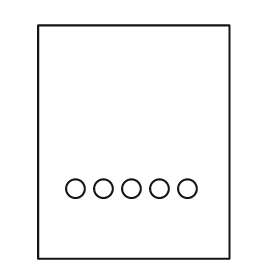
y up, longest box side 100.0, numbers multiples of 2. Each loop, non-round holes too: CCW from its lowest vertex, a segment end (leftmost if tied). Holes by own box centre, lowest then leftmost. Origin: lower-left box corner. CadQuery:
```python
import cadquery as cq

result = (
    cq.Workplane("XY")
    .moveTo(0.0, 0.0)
    .lineTo(82.0, 0.0)
    .lineTo(82.0, 100.0)
    .lineTo(0.0, 100.0)
    .close()
    .moveTo(16.0, 30.0)
    .circle(4.0)
    .moveTo(28.0, 30.0)
    .circle(4.0)
    .moveTo(40.0, 30.0)
    .circle(4.0)
    .moveTo(52.0, 30.0)
    .circle(4.0)
    .moveTo(64.0, 30.0)
    .circle(4.0)
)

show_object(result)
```